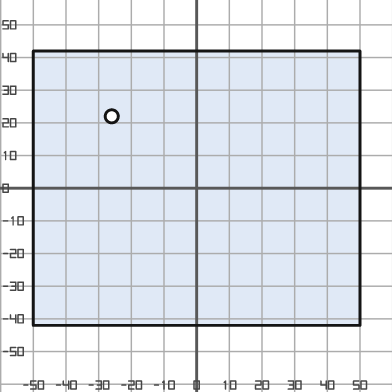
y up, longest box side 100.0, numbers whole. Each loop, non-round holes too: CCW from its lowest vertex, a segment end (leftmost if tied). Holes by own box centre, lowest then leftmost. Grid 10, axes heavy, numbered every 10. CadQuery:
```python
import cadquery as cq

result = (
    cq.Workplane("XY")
    .moveTo(-50.0, -42.0)
    .lineTo(50.0, -42.0)
    .lineTo(50.0, 42.0)
    .lineTo(-50.0, 42.0)
    .close()
    .moveTo(-26.0, 22.0)
    .circle(2.0)
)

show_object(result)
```